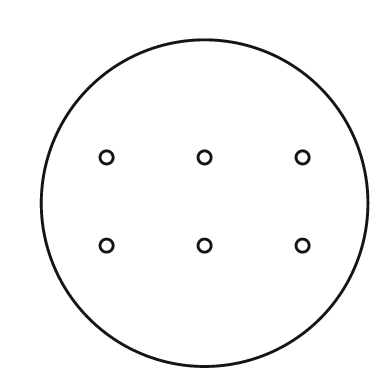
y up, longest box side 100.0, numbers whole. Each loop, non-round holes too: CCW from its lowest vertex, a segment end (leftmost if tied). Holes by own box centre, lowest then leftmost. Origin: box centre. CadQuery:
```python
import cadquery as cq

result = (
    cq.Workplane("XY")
    .moveTo(0.0, 0.0)
    .circle(50.0)
    .moveTo(-30.0, -13.0)
    .circle(2.0)
    .moveTo(0.0, -13.0)
    .circle(2.0)
    .moveTo(30.0, -13.0)
    .circle(2.0)
    .moveTo(-30.0, 14.0)
    .circle(2.0)
    .moveTo(0.0, 14.0)
    .circle(2.0)
    .moveTo(30.0, 14.0)
    .circle(2.0)
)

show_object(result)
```